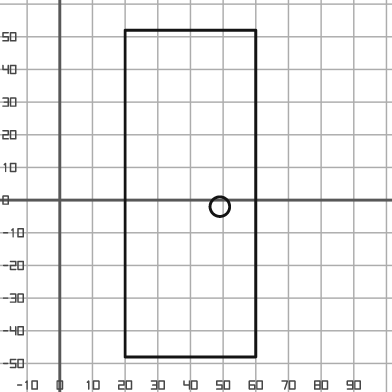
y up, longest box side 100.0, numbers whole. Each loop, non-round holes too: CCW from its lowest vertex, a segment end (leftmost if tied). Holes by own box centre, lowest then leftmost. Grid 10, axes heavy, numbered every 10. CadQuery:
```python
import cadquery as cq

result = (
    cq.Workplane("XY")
    .moveTo(20.0, -48.0)
    .lineTo(60.0, -48.0)
    .lineTo(60.0, 52.0)
    .lineTo(20.0, 52.0)
    .close()
    .moveTo(49.0, -2.0)
    .circle(3.0)
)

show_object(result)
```